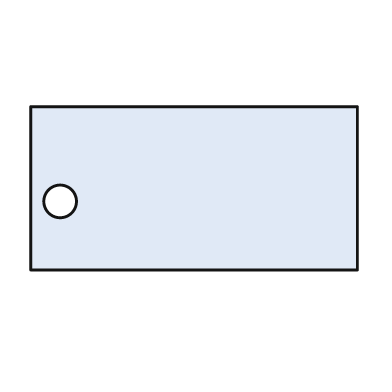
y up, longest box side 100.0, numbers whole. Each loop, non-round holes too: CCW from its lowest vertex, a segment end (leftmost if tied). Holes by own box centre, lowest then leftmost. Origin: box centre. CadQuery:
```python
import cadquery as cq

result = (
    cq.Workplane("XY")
    .moveTo(-50.0, -25.0)
    .lineTo(50.0, -25.0)
    .lineTo(50.0, 25.0)
    .lineTo(-50.0, 25.0)
    .close()
    .moveTo(-41.0, -4.0)
    .circle(5.0)
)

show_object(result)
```